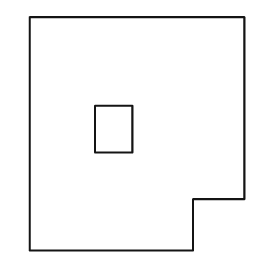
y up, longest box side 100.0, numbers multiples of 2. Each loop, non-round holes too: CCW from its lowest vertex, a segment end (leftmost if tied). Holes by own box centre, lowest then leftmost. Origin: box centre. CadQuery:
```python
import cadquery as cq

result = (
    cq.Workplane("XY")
    .moveTo(-46.0, -50.0)
    .lineTo(24.0, -50.0)
    .lineTo(24.0, -28.0)
    .lineTo(46.0, -28.0)
    .lineTo(46.0, 50.0)
    .lineTo(-46.0, 50.0)
    .close()
    .moveTo(-18.0, -8.0)
    .lineTo(-2.0, -8.0)
    .lineTo(-2.0, 12.0)
    .lineTo(-18.0, 12.0)
    .close()
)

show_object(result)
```